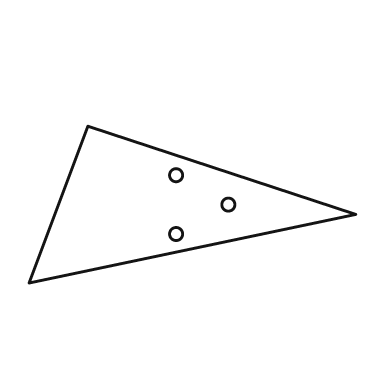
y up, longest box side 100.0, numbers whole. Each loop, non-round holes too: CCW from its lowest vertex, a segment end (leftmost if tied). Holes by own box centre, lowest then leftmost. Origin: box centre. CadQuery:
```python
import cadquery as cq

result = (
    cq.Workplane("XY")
    .moveTo(-50.0, -24.0)
    .lineTo(50.0, -3.0)
    .lineTo(-32.0, 24.0)
    .close()
    .moveTo(-5.0, -9.0)
    .circle(2.0)
    .moveTo(11.0, 0.0)
    .circle(2.0)
    .moveTo(-5.0, 9.0)
    .circle(2.0)
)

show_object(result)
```